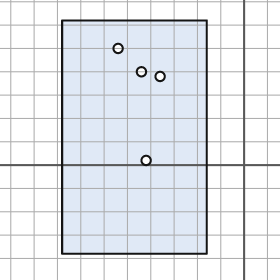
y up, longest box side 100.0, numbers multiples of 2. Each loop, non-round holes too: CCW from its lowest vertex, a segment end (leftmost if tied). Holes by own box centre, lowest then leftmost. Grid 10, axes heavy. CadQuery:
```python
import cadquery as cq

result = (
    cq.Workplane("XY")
    .moveTo(-78.0, -38.0)
    .lineTo(-16.0, -38.0)
    .lineTo(-16.0, 62.0)
    .lineTo(-78.0, 62.0)
    .close()
    .moveTo(-42.0, 2.0)
    .circle(2.0)
    .moveTo(-36.0, 38.0)
    .circle(2.0)
    .moveTo(-44.0, 40.0)
    .circle(2.0)
    .moveTo(-54.0, 50.0)
    .circle(2.0)
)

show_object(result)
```